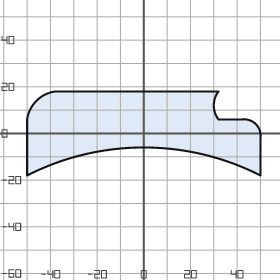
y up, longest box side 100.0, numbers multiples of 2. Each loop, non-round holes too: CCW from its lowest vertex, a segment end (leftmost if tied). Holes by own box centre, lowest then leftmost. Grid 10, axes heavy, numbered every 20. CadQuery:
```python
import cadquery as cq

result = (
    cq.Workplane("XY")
    .moveTo(-50.0, -18.0)
    .threePointArc((0.0, -6.0), (50.0, -18.0))
    .lineTo(50.0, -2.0)
    .threePointArc((48.0, 4.0), (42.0, 6.0))
    .lineTo(32.0, 6.0)
    .threePointArc((30.0, 12.0), (32.0, 18.0))
    .lineTo(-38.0, 18.0)
    .threePointArc((-46.0, 14.0), (-50.0, 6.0))
    .close()
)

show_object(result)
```